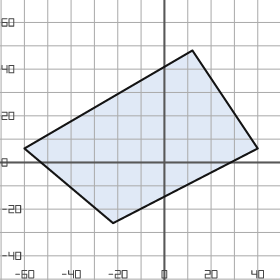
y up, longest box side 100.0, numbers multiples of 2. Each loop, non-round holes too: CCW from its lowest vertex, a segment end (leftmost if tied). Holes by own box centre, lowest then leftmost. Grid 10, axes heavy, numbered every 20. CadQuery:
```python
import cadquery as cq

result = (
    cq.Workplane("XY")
    .moveTo(-22.0, -26.0)
    .lineTo(40.0, 6.0)
    .lineTo(12.0, 48.0)
    .lineTo(-60.0, 6.0)
    .close()
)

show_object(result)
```